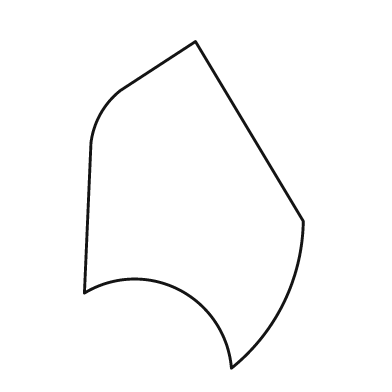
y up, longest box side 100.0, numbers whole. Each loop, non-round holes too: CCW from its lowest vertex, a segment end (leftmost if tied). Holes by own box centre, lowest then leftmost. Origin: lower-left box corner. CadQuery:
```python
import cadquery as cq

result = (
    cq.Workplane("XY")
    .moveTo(45.0, 0.0)
    .threePointArc((61.0, 20.0), (67.0, 45.0))
    .lineTo(34.0, 100.0)
    .lineTo(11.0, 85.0)
    .threePointArc((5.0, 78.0), (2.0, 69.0))
    .lineTo(0.0, 23.0)
    .threePointArc((29.0, 24.0), (45.0, 0.0))
    .close()
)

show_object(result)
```